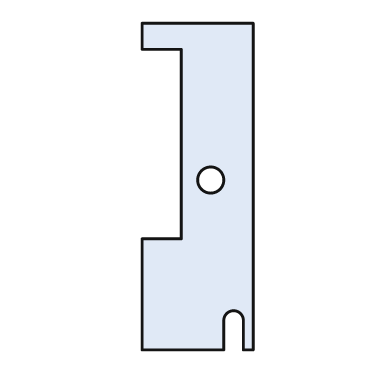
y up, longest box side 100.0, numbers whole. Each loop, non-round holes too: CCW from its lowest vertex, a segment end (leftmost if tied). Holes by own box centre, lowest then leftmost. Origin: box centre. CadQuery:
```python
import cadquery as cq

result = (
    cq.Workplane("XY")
    .moveTo(-17.0, -50.0)
    .lineTo(8.0, -50.0)
    .lineTo(8.0, -41.0)
    .threePointArc((11.0, -38.0), (14.0, -41.0))
    .lineTo(14.0, -50.0)
    .lineTo(17.0, -50.0)
    .lineTo(17.0, 50.0)
    .lineTo(-17.0, 50.0)
    .lineTo(-17.0, 42.0)
    .lineTo(-5.0, 42.0)
    .lineTo(-5.0, -16.0)
    .lineTo(-17.0, -16.0)
    .close()
    .moveTo(4.0, 2.0)
    .circle(4.0)
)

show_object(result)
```